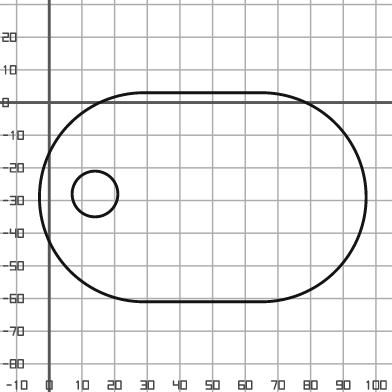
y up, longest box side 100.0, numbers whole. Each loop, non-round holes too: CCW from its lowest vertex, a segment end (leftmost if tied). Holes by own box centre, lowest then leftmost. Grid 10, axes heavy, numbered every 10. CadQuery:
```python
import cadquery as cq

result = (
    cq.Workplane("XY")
    .moveTo(29.0, -61.0)
    .lineTo(65.0, -61.0)
    .threePointArc((97.0, -29.0), (65.0, 3.0))
    .lineTo(29.0, 3.0)
    .threePointArc((-3.0, -29.0), (29.0, -61.0))
    .close()
    .moveTo(14.0, -28.0)
    .circle(7.0)
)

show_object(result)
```